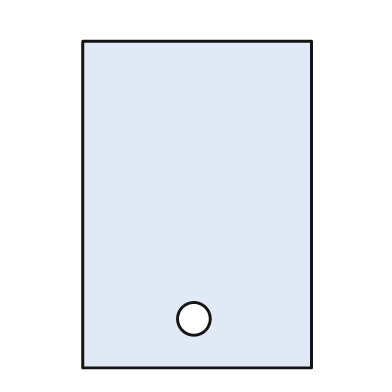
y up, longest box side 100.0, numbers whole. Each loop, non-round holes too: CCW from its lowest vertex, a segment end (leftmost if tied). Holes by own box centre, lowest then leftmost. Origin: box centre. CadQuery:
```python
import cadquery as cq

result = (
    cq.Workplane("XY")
    .moveTo(-35.0, -50.0)
    .lineTo(35.0, -50.0)
    .lineTo(35.0, 50.0)
    .lineTo(-35.0, 50.0)
    .close()
    .moveTo(-1.0, -35.0)
    .circle(5.0)
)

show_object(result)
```